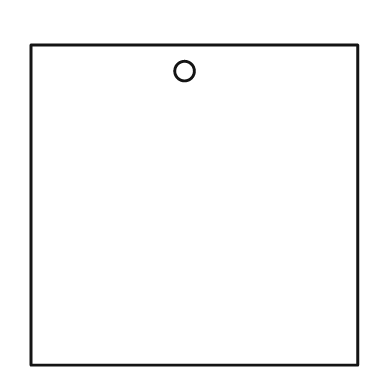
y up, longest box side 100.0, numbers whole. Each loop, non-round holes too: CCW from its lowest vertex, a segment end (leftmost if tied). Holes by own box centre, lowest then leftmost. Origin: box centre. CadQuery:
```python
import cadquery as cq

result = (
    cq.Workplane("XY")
    .moveTo(-50.0, -49.0)
    .lineTo(50.0, -49.0)
    .lineTo(50.0, 49.0)
    .lineTo(-50.0, 49.0)
    .close()
    .moveTo(-3.0, 41.0)
    .circle(3.0)
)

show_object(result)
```